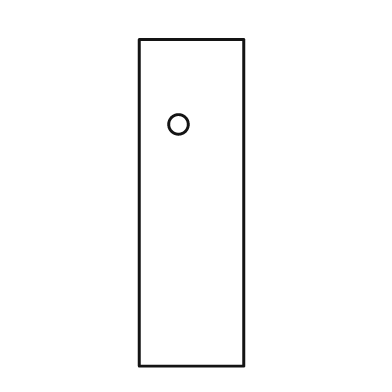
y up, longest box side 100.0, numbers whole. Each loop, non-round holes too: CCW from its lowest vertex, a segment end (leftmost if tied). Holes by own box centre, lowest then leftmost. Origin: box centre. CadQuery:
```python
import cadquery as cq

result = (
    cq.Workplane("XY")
    .moveTo(-16.0, -50.0)
    .lineTo(16.0, -50.0)
    .lineTo(16.0, 50.0)
    .lineTo(-16.0, 50.0)
    .close()
    .moveTo(-4.0, 24.0)
    .circle(3.0)
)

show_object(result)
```